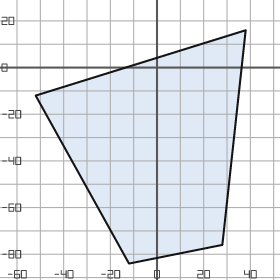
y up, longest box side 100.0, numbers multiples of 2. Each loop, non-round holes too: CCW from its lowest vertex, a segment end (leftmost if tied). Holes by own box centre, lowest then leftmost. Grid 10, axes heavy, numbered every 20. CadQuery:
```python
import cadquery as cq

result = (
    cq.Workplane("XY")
    .moveTo(-12.0, -84.0)
    .lineTo(28.0, -76.0)
    .lineTo(38.0, 16.0)
    .lineTo(-52.0, -12.0)
    .close()
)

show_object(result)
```